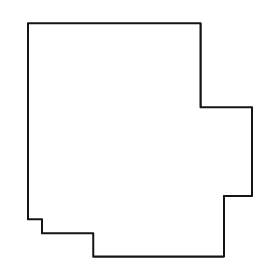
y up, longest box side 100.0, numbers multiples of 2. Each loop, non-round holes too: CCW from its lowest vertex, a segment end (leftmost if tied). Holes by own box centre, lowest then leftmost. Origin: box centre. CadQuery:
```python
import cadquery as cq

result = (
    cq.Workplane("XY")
    .moveTo(-20.0, -50.0)
    .lineTo(36.0, -50.0)
    .lineTo(36.0, -24.0)
    .lineTo(48.0, -24.0)
    .lineTo(48.0, 14.0)
    .lineTo(26.0, 14.0)
    .lineTo(26.0, 50.0)
    .lineTo(-48.0, 50.0)
    .lineTo(-48.0, -34.0)
    .lineTo(-42.0, -34.0)
    .lineTo(-42.0, -40.0)
    .lineTo(-20.0, -40.0)
    .close()
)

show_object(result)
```